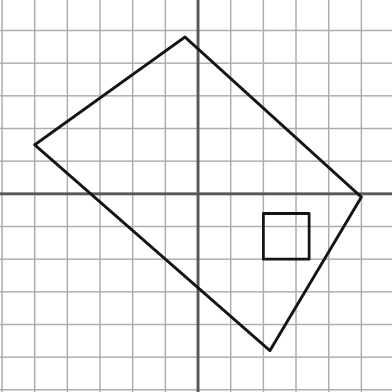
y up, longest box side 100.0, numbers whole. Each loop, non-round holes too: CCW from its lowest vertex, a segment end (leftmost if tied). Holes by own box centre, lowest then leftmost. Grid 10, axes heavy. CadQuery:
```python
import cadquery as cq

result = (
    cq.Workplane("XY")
    .moveTo(22.0, -48.0)
    .lineTo(50.0, -1.0)
    .lineTo(-4.0, 48.0)
    .lineTo(-50.0, 15.0)
    .close()
    .moveTo(20.0, -20.0)
    .lineTo(34.0, -20.0)
    .lineTo(34.0, -6.0)
    .lineTo(20.0, -6.0)
    .close()
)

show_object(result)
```